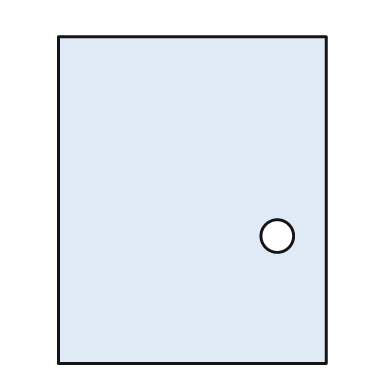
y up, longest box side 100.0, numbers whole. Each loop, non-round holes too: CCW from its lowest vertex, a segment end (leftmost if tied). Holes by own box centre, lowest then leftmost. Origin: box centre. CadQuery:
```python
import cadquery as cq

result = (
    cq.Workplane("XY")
    .moveTo(-41.0, -50.0)
    .lineTo(41.0, -50.0)
    .lineTo(41.0, 50.0)
    .lineTo(-41.0, 50.0)
    .close()
    .moveTo(26.0, -11.0)
    .circle(5.0)
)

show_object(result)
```